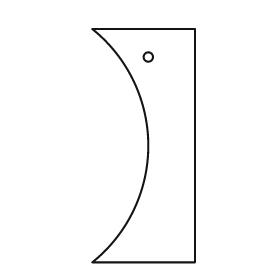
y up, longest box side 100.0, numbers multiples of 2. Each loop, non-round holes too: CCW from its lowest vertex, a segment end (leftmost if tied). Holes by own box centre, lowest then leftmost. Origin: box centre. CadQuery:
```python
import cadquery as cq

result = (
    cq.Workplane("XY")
    .moveTo(-22.0, -50.0)
    .lineTo(22.0, -50.0)
    .lineTo(22.0, 50.0)
    .lineTo(-22.0, 50.0)
    .threePointArc((2.0, 0.0), (-22.0, -50.0))
    .close()
    .moveTo(2.0, 38.0)
    .circle(2.0)
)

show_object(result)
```